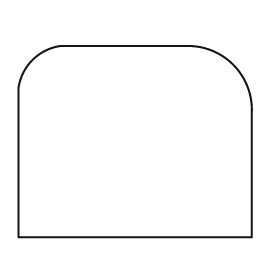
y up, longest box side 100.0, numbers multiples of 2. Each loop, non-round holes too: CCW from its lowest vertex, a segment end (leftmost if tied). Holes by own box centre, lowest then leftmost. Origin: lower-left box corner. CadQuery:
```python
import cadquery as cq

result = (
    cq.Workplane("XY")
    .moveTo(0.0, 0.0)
    .lineTo(100.0, 0.0)
    .lineTo(100.0, 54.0)
    .threePointArc((92.0, 74.0), (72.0, 82.0))
    .lineTo(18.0, 82.0)
    .threePointArc((6.0, 76.0), (0.0, 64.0))
    .close()
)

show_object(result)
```